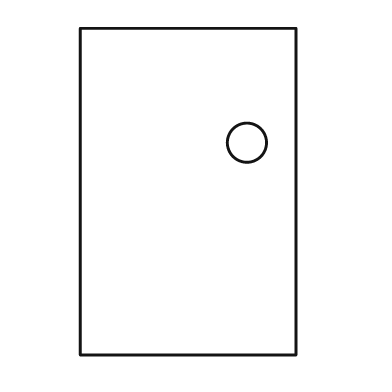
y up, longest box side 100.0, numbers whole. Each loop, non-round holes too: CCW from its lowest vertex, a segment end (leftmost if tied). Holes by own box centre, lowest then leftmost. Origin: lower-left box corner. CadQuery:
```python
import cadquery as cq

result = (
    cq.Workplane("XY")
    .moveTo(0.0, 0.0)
    .lineTo(66.0, 0.0)
    .lineTo(66.0, 100.0)
    .lineTo(0.0, 100.0)
    .close()
    .moveTo(51.0, 65.0)
    .circle(6.0)
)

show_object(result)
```